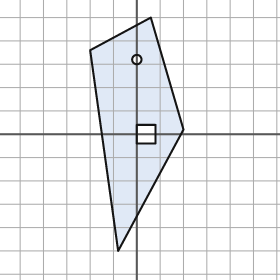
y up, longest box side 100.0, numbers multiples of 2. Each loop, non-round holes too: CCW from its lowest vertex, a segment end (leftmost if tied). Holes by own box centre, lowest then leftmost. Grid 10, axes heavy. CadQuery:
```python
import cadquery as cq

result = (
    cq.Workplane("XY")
    .moveTo(-8.0, -50.0)
    .lineTo(20.0, 2.0)
    .lineTo(6.0, 50.0)
    .lineTo(-20.0, 36.0)
    .close()
    .moveTo(0.0, -4.0)
    .lineTo(8.0, -4.0)
    .lineTo(8.0, 4.0)
    .lineTo(0.0, 4.0)
    .close()
    .moveTo(0.0, 32.0)
    .circle(2.0)
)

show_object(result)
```